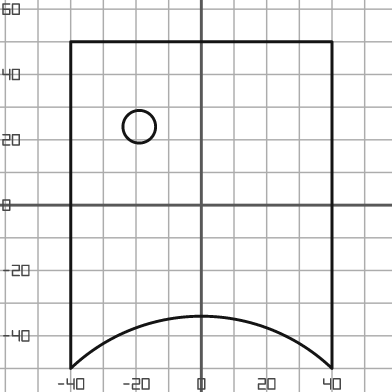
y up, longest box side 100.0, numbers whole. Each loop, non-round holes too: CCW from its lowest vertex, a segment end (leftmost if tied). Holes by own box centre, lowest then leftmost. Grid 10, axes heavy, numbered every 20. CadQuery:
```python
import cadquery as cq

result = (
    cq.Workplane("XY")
    .moveTo(-40.0, -50.0)
    .threePointArc((0.0, -34.0), (40.0, -50.0))
    .lineTo(40.0, 50.0)
    .lineTo(-40.0, 50.0)
    .close()
    .moveTo(-19.0, 24.0)
    .circle(5.0)
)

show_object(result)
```